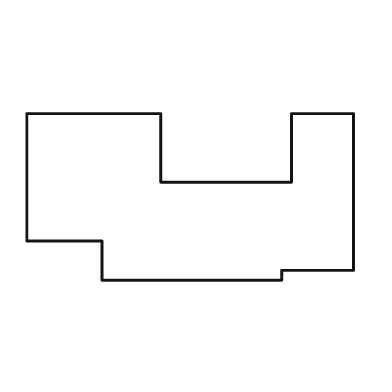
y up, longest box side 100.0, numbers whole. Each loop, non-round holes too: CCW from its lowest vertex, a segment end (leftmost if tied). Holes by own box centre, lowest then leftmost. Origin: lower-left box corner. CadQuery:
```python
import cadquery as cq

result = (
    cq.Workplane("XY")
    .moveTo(23.0, 0.0)
    .lineTo(78.0, 0.0)
    .lineTo(78.0, 3.0)
    .lineTo(100.0, 3.0)
    .lineTo(100.0, 51.0)
    .lineTo(81.0, 51.0)
    .lineTo(81.0, 30.0)
    .lineTo(41.0, 30.0)
    .lineTo(41.0, 51.0)
    .lineTo(0.0, 51.0)
    .lineTo(0.0, 12.0)
    .lineTo(23.0, 12.0)
    .close()
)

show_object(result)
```